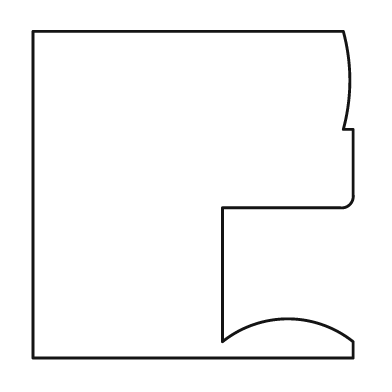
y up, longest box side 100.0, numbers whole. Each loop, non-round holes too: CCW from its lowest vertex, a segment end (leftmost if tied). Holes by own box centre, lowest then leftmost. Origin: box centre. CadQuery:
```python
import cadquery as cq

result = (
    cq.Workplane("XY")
    .moveTo(-49.0, -50.0)
    .lineTo(49.0, -50.0)
    .lineTo(49.0, -45.0)
    .threePointArc((29.0, -38.0), (9.0, -45.0))
    .lineTo(9.0, -4.0)
    .lineTo(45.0, -4.0)
    .threePointArc((48.0, -3.0), (49.0, 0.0))
    .lineTo(49.0, 20.0)
    .lineTo(46.0, 20.0)
    .threePointArc((48.0, 35.0), (46.0, 50.0))
    .lineTo(-49.0, 50.0)
    .close()
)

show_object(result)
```